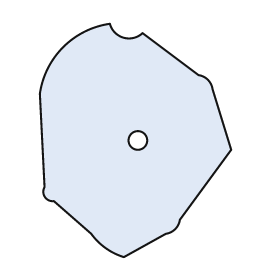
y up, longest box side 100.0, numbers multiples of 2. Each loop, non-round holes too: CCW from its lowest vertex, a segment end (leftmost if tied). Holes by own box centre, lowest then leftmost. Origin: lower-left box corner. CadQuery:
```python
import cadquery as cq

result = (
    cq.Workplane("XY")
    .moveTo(36.0, 0.0)
    .lineTo(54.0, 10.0)
    .threePointArc((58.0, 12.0), (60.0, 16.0))
    .lineTo(82.0, 46.0)
    .lineTo(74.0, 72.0)
    .threePointArc((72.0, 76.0), (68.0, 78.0))
    .lineTo(44.0, 96.0)
    .threePointArc((36.0, 94.0), (30.0, 100.0))
    .threePointArc((10.0, 90.0), (0.0, 70.0))
    .lineTo(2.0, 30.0)
    .threePointArc((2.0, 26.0), (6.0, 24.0))
    .lineTo(22.0, 10.0)
    .threePointArc((28.0, 4.0), (36.0, 0.0))
    .close()
    .moveTo(42.0, 50.0)
    .circle(4.0)
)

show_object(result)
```